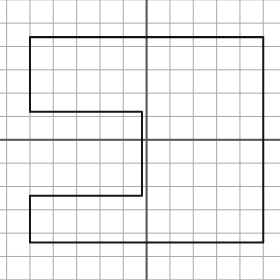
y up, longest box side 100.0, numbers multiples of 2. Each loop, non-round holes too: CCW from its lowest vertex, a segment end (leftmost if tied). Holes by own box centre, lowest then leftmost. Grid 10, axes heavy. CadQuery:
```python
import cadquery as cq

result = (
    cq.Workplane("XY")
    .moveTo(-50.0, -44.0)
    .lineTo(50.0, -44.0)
    .lineTo(50.0, 44.0)
    .lineTo(-50.0, 44.0)
    .lineTo(-50.0, 12.0)
    .lineTo(-2.0, 12.0)
    .lineTo(-2.0, -24.0)
    .lineTo(-50.0, -24.0)
    .close()
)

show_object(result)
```